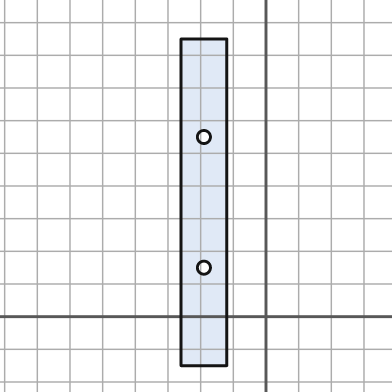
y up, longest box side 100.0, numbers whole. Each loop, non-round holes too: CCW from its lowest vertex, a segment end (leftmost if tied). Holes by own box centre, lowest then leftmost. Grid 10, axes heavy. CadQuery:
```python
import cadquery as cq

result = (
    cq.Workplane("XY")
    .moveTo(-26.0, -15.0)
    .lineTo(-12.0, -15.0)
    .lineTo(-12.0, 85.0)
    .lineTo(-26.0, 85.0)
    .close()
    .moveTo(-19.0, 15.0)
    .circle(2.0)
    .moveTo(-19.0, 55.0)
    .circle(2.0)
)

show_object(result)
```